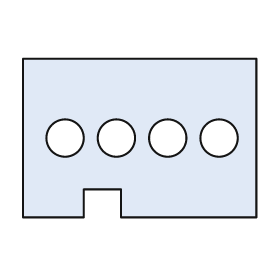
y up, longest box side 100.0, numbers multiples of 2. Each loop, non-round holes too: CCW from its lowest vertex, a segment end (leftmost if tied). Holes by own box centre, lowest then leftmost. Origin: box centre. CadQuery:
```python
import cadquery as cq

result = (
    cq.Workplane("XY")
    .moveTo(-50.0, -34.0)
    .lineTo(-24.0, -34.0)
    .lineTo(-24.0, -22.0)
    .lineTo(-8.0, -22.0)
    .lineTo(-8.0, -34.0)
    .lineTo(50.0, -34.0)
    .lineTo(50.0, 34.0)
    .lineTo(-50.0, 34.0)
    .close()
    .moveTo(-32.0, 0.0)
    .circle(8.0)
    .moveTo(-10.0, 0.0)
    .circle(8.0)
    .moveTo(12.0, 0.0)
    .circle(8.0)
    .moveTo(34.0, 0.0)
    .circle(8.0)
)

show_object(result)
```